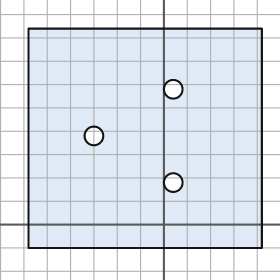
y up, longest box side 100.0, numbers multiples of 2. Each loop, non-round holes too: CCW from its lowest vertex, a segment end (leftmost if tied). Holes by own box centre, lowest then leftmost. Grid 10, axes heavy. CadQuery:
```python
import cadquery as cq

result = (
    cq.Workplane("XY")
    .moveTo(-58.0, -10.0)
    .lineTo(42.0, -10.0)
    .lineTo(42.0, 84.0)
    .lineTo(-58.0, 84.0)
    .close()
    .moveTo(4.0, 18.0)
    .circle(4.0)
    .moveTo(-30.0, 38.0)
    .circle(4.0)
    .moveTo(4.0, 58.0)
    .circle(4.0)
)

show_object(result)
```